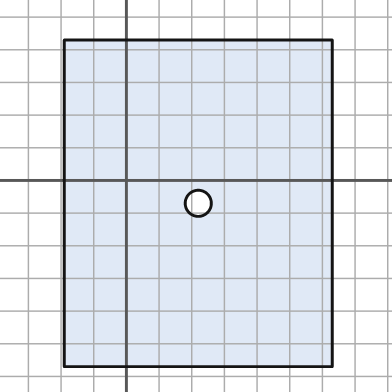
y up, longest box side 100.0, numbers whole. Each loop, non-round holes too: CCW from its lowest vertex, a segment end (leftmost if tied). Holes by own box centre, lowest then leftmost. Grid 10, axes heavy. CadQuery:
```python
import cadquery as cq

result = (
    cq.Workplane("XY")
    .moveTo(-19.0, -57.0)
    .lineTo(63.0, -57.0)
    .lineTo(63.0, 43.0)
    .lineTo(-19.0, 43.0)
    .close()
    .moveTo(22.0, -7.0)
    .circle(4.0)
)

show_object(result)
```